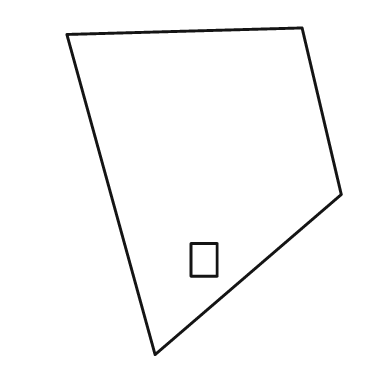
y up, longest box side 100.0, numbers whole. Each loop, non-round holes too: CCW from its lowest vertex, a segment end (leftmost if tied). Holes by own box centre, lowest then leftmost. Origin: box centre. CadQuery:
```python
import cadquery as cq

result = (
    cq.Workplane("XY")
    .moveTo(-15.0, -50.0)
    .lineTo(42.0, -1.0)
    .lineTo(30.0, 50.0)
    .lineTo(-42.0, 48.0)
    .close()
    .moveTo(-4.0, -26.0)
    .lineTo(4.0, -26.0)
    .lineTo(4.0, -16.0)
    .lineTo(-4.0, -16.0)
    .close()
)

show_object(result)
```